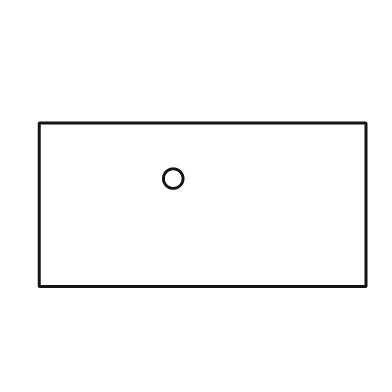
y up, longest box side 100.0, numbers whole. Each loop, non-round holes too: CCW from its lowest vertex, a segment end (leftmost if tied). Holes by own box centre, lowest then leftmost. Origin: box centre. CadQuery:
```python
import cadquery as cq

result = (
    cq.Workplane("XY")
    .moveTo(-50.0, -25.0)
    .lineTo(50.0, -25.0)
    .lineTo(50.0, 25.0)
    .lineTo(-50.0, 25.0)
    .close()
    .moveTo(-9.0, 8.0)
    .circle(3.0)
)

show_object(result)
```